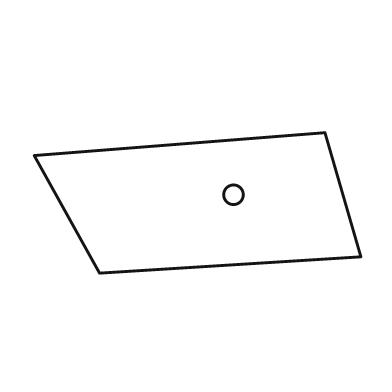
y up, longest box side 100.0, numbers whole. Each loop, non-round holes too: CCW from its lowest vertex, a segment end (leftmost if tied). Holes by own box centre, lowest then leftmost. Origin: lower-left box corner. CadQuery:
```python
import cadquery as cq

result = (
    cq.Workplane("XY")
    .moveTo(20.0, 0.0)
    .lineTo(100.0, 5.0)
    .lineTo(89.0, 43.0)
    .lineTo(0.0, 36.0)
    .close()
    .moveTo(61.0, 24.0)
    .circle(3.0)
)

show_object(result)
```